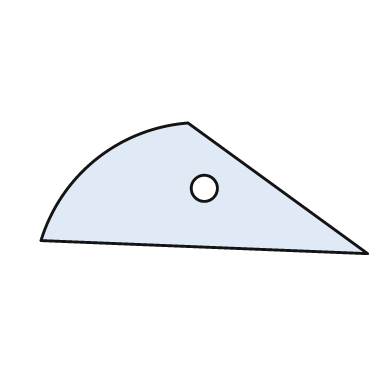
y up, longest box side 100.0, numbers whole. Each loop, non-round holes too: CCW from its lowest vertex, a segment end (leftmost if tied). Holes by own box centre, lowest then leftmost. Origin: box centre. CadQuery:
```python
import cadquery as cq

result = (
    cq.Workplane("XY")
    .moveTo(50.0, -20.0)
    .lineTo(-5.0, 20.0)
    .threePointArc((-33.0, 9.0), (-50.0, -16.0))
    .close()
    .moveTo(0.0, 0.0)
    .circle(4.0)
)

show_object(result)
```